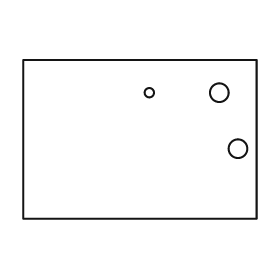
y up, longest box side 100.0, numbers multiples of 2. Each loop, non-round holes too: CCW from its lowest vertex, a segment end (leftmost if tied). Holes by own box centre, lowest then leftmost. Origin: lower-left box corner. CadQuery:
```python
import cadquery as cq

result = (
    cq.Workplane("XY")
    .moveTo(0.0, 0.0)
    .lineTo(100.0, 0.0)
    .lineTo(100.0, 68.0)
    .lineTo(0.0, 68.0)
    .close()
    .moveTo(92.0, 30.0)
    .circle(4.0)
    .moveTo(54.0, 54.0)
    .circle(2.0)
    .moveTo(84.0, 54.0)
    .circle(4.0)
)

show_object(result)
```